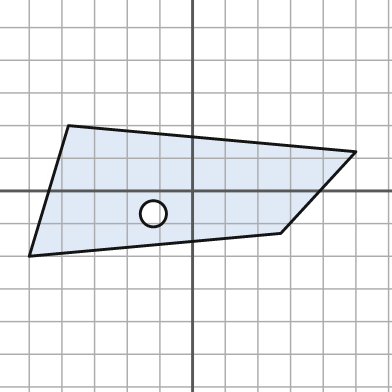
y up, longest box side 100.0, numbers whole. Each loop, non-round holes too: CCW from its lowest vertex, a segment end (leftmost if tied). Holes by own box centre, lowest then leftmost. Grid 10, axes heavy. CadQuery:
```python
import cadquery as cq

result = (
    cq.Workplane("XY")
    .moveTo(-50.0, -20.0)
    .lineTo(27.0, -13.0)
    .lineTo(50.0, 12.0)
    .lineTo(-38.0, 20.0)
    .close()
    .moveTo(-12.0, -7.0)
    .circle(4.0)
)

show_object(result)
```